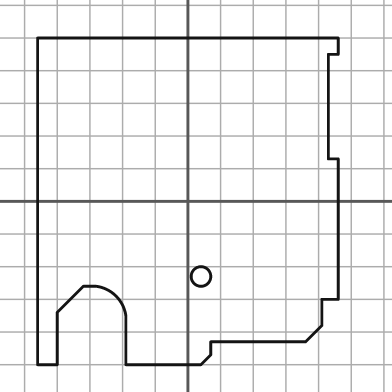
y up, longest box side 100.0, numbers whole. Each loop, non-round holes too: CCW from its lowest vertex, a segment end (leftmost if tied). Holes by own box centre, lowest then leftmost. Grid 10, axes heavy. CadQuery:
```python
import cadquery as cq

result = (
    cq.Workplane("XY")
    .moveTo(-46.0, -50.0)
    .lineTo(-40.0, -50.0)
    .lineTo(-40.0, -34.0)
    .lineTo(-32.0, -26.0)
    .lineTo(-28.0, -26.0)
    .threePointArc((-22.0, -29.0), (-19.0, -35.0))
    .lineTo(-19.0, -50.0)
    .lineTo(4.0, -50.0)
    .lineTo(7.0, -47.0)
    .lineTo(7.0, -43.0)
    .lineTo(36.0, -43.0)
    .lineTo(41.0, -38.0)
    .lineTo(41.0, -30.0)
    .lineTo(46.0, -30.0)
    .lineTo(46.0, 13.0)
    .lineTo(43.0, 13.0)
    .lineTo(43.0, 45.0)
    .lineTo(46.0, 45.0)
    .lineTo(46.0, 50.0)
    .lineTo(-46.0, 50.0)
    .close()
    .moveTo(4.0, -23.0)
    .circle(3.0)
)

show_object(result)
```